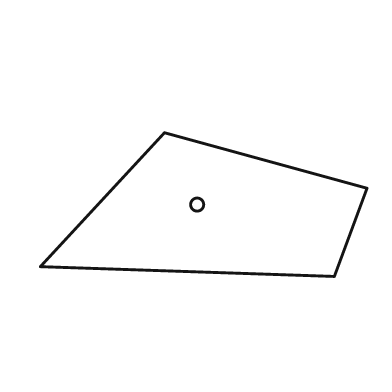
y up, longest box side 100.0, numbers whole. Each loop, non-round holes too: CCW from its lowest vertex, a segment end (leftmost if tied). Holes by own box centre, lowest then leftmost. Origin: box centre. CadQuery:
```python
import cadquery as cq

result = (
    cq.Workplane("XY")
    .moveTo(40.0, -22.0)
    .lineTo(50.0, 5.0)
    .lineTo(-12.0, 22.0)
    .lineTo(-50.0, -19.0)
    .close()
    .moveTo(-2.0, 0.0)
    .circle(2.0)
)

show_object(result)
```